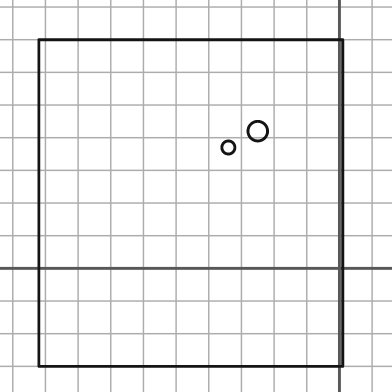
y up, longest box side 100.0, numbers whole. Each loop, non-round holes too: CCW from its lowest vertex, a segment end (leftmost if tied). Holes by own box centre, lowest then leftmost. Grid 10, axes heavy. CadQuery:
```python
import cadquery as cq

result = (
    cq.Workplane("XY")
    .moveTo(-92.0, -30.0)
    .lineTo(1.0, -30.0)
    .lineTo(1.0, 70.0)
    .lineTo(-92.0, 70.0)
    .close()
    .moveTo(-34.0, 37.0)
    .circle(2.0)
    .moveTo(-25.0, 42.0)
    .circle(3.0)
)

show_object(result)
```